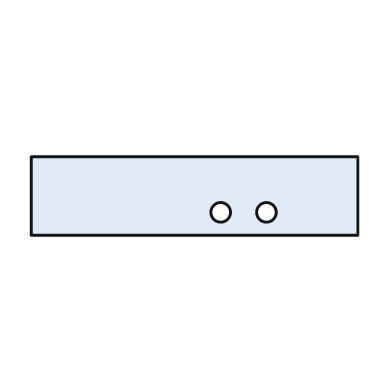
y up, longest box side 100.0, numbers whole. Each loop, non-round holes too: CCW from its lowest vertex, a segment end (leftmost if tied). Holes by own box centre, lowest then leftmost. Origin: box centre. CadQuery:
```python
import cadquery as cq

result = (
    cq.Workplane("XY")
    .moveTo(-50.0, -12.0)
    .lineTo(50.0, -12.0)
    .lineTo(50.0, 12.0)
    .lineTo(-50.0, 12.0)
    .close()
    .moveTo(8.0, -5.0)
    .circle(3.0)
    .moveTo(22.0, -5.0)
    .circle(3.0)
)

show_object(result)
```